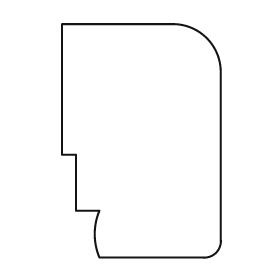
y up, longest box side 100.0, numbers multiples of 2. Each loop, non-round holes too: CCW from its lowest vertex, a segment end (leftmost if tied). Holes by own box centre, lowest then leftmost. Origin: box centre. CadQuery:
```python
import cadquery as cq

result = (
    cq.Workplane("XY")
    .moveTo(-18.0, -50.0)
    .lineTo(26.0, -50.0)
    .threePointArc((32.0, -48.0), (34.0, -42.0))
    .lineTo(34.0, 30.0)
    .threePointArc((28.0, 44.0), (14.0, 50.0))
    .lineTo(-34.0, 50.0)
    .lineTo(-34.0, -6.0)
    .lineTo(-28.0, -6.0)
    .lineTo(-28.0, -30.0)
    .lineTo(-18.0, -30.0)
    .threePointArc((-20.0, -40.0), (-18.0, -50.0))
    .close()
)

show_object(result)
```